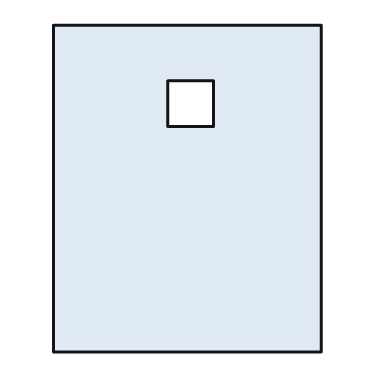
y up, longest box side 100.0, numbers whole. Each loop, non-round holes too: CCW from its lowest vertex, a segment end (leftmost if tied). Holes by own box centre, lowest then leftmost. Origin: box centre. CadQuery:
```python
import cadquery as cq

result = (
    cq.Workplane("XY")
    .moveTo(-41.0, -50.0)
    .lineTo(41.0, -50.0)
    .lineTo(41.0, 50.0)
    .lineTo(-41.0, 50.0)
    .close()
    .moveTo(-6.0, 19.0)
    .lineTo(8.0, 19.0)
    .lineTo(8.0, 33.0)
    .lineTo(-6.0, 33.0)
    .close()
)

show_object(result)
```